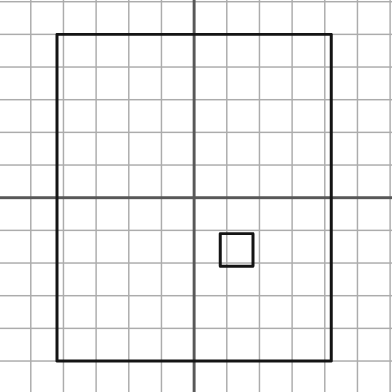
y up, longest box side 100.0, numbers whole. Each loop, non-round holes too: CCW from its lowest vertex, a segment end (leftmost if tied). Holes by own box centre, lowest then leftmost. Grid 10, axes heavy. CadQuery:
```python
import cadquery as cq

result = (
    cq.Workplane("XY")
    .moveTo(-42.0, -50.0)
    .lineTo(42.0, -50.0)
    .lineTo(42.0, 50.0)
    .lineTo(-42.0, 50.0)
    .close()
    .moveTo(8.0, -21.0)
    .lineTo(18.0, -21.0)
    .lineTo(18.0, -11.0)
    .lineTo(8.0, -11.0)
    .close()
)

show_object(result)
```